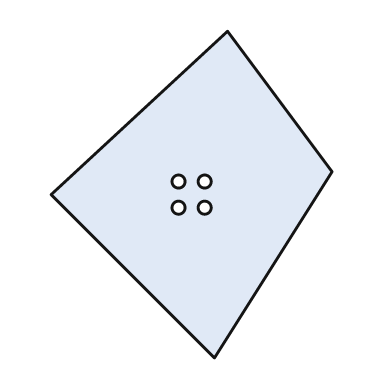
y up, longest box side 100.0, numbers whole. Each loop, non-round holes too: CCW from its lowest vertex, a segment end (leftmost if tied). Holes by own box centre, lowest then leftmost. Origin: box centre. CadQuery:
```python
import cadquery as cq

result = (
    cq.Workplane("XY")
    .moveTo(7.0, -50.0)
    .lineTo(43.0, 7.0)
    .lineTo(11.0, 50.0)
    .lineTo(-43.0, 0.0)
    .close()
    .moveTo(-4.0, -4.0)
    .circle(2.0)
    .moveTo(4.0, -4.0)
    .circle(2.0)
    .moveTo(-4.0, 4.0)
    .circle(2.0)
    .moveTo(4.0, 4.0)
    .circle(2.0)
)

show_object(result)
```